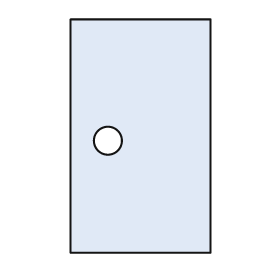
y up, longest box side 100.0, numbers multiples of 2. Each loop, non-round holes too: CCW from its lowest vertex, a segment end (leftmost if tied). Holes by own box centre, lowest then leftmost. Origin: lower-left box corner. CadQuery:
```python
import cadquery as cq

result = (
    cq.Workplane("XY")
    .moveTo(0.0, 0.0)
    .lineTo(60.0, 0.0)
    .lineTo(60.0, 100.0)
    .lineTo(0.0, 100.0)
    .close()
    .moveTo(16.0, 48.0)
    .circle(6.0)
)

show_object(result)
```